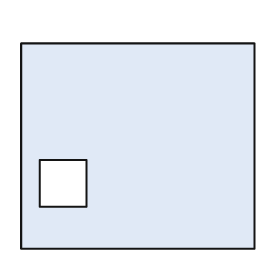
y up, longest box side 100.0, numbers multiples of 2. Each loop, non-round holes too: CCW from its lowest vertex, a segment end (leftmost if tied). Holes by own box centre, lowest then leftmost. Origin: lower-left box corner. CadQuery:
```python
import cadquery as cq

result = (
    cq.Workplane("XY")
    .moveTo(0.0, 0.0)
    .lineTo(100.0, 0.0)
    .lineTo(100.0, 88.0)
    .lineTo(0.0, 88.0)
    .close()
    .moveTo(8.0, 18.0)
    .lineTo(28.0, 18.0)
    .lineTo(28.0, 38.0)
    .lineTo(8.0, 38.0)
    .close()
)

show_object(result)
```